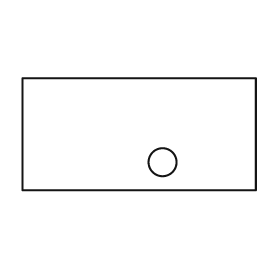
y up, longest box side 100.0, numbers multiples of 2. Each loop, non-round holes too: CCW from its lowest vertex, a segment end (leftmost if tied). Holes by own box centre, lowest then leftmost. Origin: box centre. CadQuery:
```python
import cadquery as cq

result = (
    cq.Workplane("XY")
    .moveTo(-50.0, -24.0)
    .lineTo(50.0, -24.0)
    .lineTo(50.0, 24.0)
    .lineTo(-50.0, 24.0)
    .close()
    .moveTo(10.0, -12.0)
    .circle(6.0)
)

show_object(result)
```